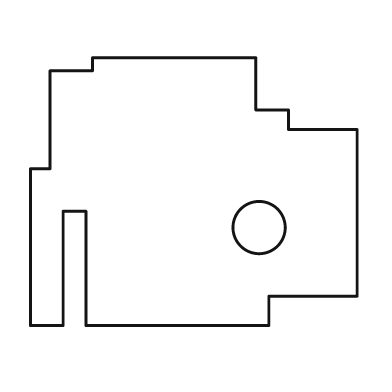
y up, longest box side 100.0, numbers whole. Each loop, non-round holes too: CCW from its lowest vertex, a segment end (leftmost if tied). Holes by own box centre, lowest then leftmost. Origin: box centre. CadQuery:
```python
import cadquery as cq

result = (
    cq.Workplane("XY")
    .moveTo(-50.0, -41.0)
    .lineTo(-40.0, -41.0)
    .lineTo(-40.0, -6.0)
    .lineTo(-33.0, -6.0)
    .lineTo(-33.0, -41.0)
    .lineTo(23.0, -41.0)
    .lineTo(23.0, -32.0)
    .lineTo(50.0, -32.0)
    .lineTo(50.0, 19.0)
    .lineTo(29.0, 19.0)
    .lineTo(29.0, 25.0)
    .lineTo(19.0, 25.0)
    .lineTo(19.0, 41.0)
    .lineTo(-31.0, 41.0)
    .lineTo(-31.0, 37.0)
    .lineTo(-44.0, 37.0)
    .lineTo(-44.0, 7.0)
    .lineTo(-50.0, 7.0)
    .close()
    .moveTo(20.0, -11.0)
    .circle(8.0)
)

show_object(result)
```